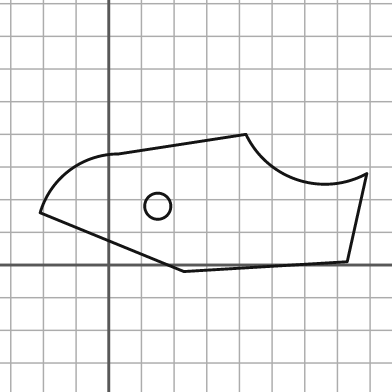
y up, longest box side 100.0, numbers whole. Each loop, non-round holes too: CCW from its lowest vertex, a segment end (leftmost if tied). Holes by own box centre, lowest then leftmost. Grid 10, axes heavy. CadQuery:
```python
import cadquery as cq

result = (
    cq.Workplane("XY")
    .moveTo(23.0, -2.0)
    .lineTo(73.0, 1.0)
    .lineTo(79.0, 28.0)
    .threePointArc((58.0, 26.0), (42.0, 40.0))
    .lineTo(3.0, 34.0)
    .threePointArc((-12.0, 29.0), (-21.0, 16.0))
    .close()
    .moveTo(15.0, 18.0)
    .circle(4.0)
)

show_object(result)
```